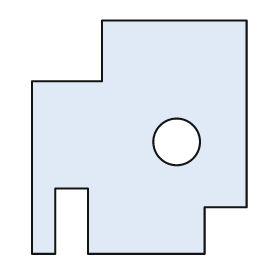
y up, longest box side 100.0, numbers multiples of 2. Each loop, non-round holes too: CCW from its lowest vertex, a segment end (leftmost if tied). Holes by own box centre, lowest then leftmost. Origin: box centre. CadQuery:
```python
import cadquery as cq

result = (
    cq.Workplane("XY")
    .moveTo(-46.0, -50.0)
    .lineTo(-36.0, -50.0)
    .lineTo(-36.0, -22.0)
    .lineTo(-22.0, -22.0)
    .lineTo(-22.0, -50.0)
    .lineTo(28.0, -50.0)
    .lineTo(28.0, -30.0)
    .lineTo(46.0, -30.0)
    .lineTo(46.0, 50.0)
    .lineTo(-16.0, 50.0)
    .lineTo(-16.0, 24.0)
    .lineTo(-46.0, 24.0)
    .close()
    .moveTo(16.0, -2.0)
    .circle(10.0)
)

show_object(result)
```